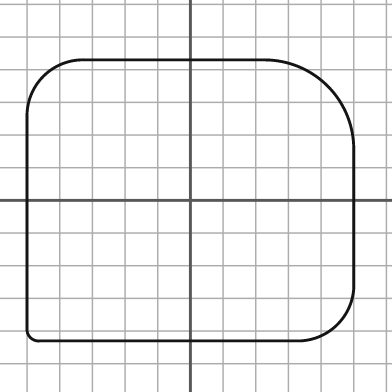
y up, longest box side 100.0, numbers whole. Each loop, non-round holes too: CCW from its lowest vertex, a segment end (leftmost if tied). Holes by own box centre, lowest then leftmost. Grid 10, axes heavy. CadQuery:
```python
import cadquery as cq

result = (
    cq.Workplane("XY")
    .moveTo(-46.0, -43.0)
    .lineTo(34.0, -43.0)
    .threePointArc((45.0, -38.0), (50.0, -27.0))
    .lineTo(50.0, 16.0)
    .threePointArc((42.0, 35.0), (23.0, 43.0))
    .lineTo(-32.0, 43.0)
    .threePointArc((-45.0, 38.0), (-50.0, 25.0))
    .lineTo(-50.0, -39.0)
    .threePointArc((-49.0, -42.0), (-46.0, -43.0))
    .close()
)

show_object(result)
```